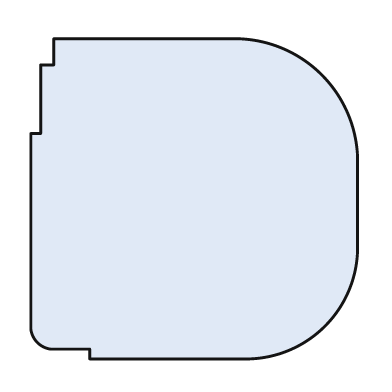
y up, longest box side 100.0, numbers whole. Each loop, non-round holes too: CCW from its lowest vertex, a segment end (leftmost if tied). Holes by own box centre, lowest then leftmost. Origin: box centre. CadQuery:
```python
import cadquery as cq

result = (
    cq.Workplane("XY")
    .moveTo(-32.0, -49.0)
    .lineTo(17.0, -49.0)
    .threePointArc((40.0, -39.0), (50.0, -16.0))
    .lineTo(50.0, 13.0)
    .threePointArc((39.0, 38.0), (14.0, 49.0))
    .lineTo(-43.0, 49.0)
    .lineTo(-43.0, 41.0)
    .lineTo(-47.0, 41.0)
    .lineTo(-47.0, 20.0)
    .lineTo(-50.0, 20.0)
    .lineTo(-50.0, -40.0)
    .threePointArc((-48.0, -44.0), (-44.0, -46.0))
    .lineTo(-32.0, -46.0)
    .close()
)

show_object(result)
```